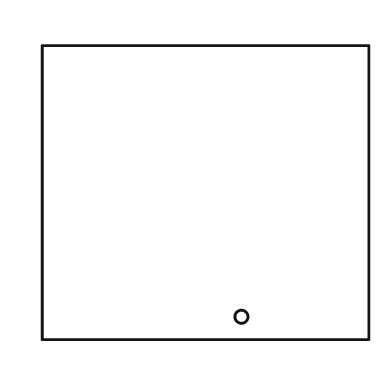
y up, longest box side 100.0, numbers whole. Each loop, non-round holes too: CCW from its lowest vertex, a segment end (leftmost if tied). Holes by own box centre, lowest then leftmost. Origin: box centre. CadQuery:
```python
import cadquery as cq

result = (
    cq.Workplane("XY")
    .moveTo(-50.0, -45.0)
    .lineTo(50.0, -45.0)
    .lineTo(50.0, 45.0)
    .lineTo(-50.0, 45.0)
    .close()
    .moveTo(11.0, -38.0)
    .circle(2.0)
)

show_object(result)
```